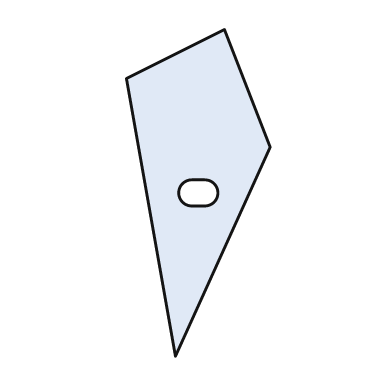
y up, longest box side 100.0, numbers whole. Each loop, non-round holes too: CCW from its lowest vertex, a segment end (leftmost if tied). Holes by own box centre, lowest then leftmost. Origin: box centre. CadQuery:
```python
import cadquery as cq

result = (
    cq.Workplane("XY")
    .moveTo(-7.0, -50.0)
    .lineTo(22.0, 14.0)
    .lineTo(8.0, 50.0)
    .lineTo(-22.0, 35.0)
    .close()
    .moveTo(-2.0, -4.0)
    .lineTo(2.0, -4.0)
    .threePointArc((6.0, 0.0), (2.0, 4.0))
    .lineTo(-2.0, 4.0)
    .threePointArc((-6.0, 0.0), (-2.0, -4.0))
    .close()
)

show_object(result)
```